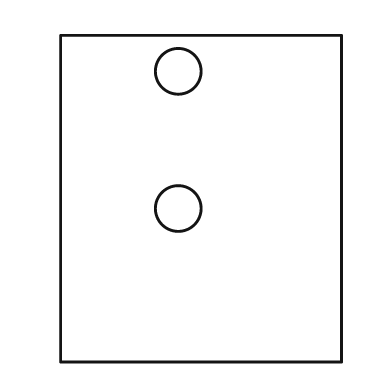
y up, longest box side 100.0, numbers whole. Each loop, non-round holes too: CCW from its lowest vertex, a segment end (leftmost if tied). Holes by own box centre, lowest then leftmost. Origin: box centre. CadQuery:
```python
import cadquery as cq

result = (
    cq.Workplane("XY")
    .moveTo(-43.0, -50.0)
    .lineTo(43.0, -50.0)
    .lineTo(43.0, 50.0)
    .lineTo(-43.0, 50.0)
    .close()
    .moveTo(-7.0, -3.0)
    .circle(7.0)
    .moveTo(-7.0, 39.0)
    .circle(7.0)
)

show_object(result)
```